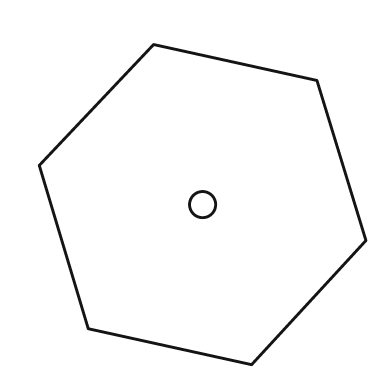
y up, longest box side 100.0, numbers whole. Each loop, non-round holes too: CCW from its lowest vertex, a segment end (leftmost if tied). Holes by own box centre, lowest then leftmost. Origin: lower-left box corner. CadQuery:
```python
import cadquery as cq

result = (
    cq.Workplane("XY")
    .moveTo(65.0, 0.0)
    .lineTo(100.0, 38.0)
    .lineTo(85.0, 87.0)
    .lineTo(35.0, 98.0)
    .lineTo(0.0, 61.0)
    .lineTo(15.0, 11.0)
    .close()
    .moveTo(50.0, 49.0)
    .circle(4.0)
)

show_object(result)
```